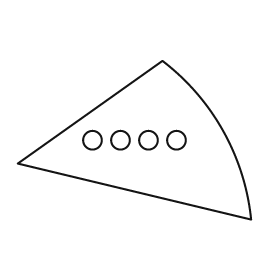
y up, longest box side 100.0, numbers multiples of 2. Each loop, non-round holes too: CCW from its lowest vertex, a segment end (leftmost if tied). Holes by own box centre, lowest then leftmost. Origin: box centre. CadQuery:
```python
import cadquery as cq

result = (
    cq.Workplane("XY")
    .moveTo(50.0, -34.0)
    .threePointArc((38.0, 4.0), (12.0, 34.0))
    .lineTo(-50.0, -10.0)
    .close()
    .moveTo(-18.0, 0.0)
    .circle(4.0)
    .moveTo(-6.0, 0.0)
    .circle(4.0)
    .moveTo(6.0, 0.0)
    .circle(4.0)
    .moveTo(18.0, 0.0)
    .circle(4.0)
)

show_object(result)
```